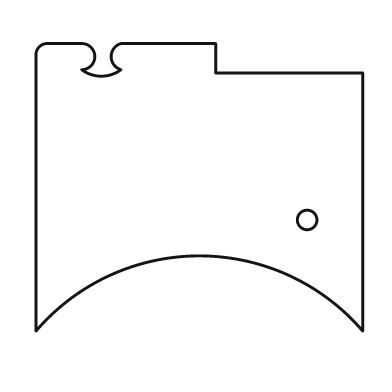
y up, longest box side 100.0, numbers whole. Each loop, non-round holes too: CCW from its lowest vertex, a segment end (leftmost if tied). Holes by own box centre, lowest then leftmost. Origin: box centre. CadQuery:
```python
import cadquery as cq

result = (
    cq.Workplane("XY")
    .moveTo(-50.0, -44.0)
    .threePointArc((0.0, -21.0), (50.0, -44.0))
    .lineTo(50.0, 35.0)
    .lineTo(5.0, 35.0)
    .lineTo(5.0, 44.0)
    .lineTo(-24.0, 44.0)
    .threePointArc((-27.0, 40.0), (-24.0, 36.0))
    .threePointArc((-30.0, 34.0), (-36.0, 36.0))
    .threePointArc((-32.0, 40.0), (-36.0, 44.0))
    .lineTo(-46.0, 44.0)
    .threePointArc((-49.0, 43.0), (-50.0, 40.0))
    .close()
    .moveTo(33.0, -10.0)
    .circle(3.0)
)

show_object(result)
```